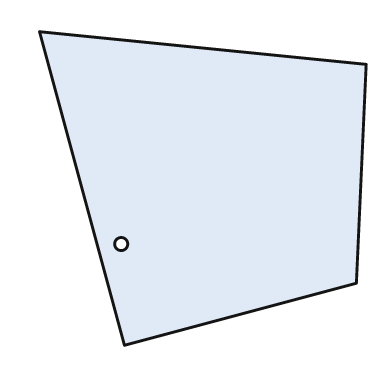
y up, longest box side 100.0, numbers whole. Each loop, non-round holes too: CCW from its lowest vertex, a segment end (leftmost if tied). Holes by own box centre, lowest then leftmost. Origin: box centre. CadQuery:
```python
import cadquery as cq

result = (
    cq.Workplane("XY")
    .moveTo(-24.0, -48.0)
    .lineTo(47.0, -29.0)
    .lineTo(50.0, 38.0)
    .lineTo(-50.0, 48.0)
    .close()
    .moveTo(-25.0, -17.0)
    .circle(2.0)
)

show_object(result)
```